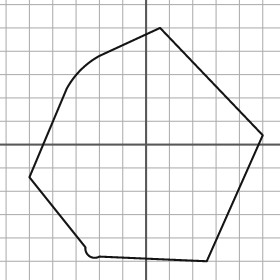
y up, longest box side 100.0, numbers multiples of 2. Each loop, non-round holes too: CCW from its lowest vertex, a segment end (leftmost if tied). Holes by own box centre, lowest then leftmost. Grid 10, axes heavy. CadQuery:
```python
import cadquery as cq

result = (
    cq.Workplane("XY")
    .moveTo(26.0, -50.0)
    .lineTo(50.0, 4.0)
    .lineTo(6.0, 50.0)
    .lineTo(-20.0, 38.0)
    .threePointArc((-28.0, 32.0), (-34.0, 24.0))
    .lineTo(-50.0, -14.0)
    .lineTo(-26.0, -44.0)
    .threePointArc((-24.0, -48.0), (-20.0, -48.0))
    .close()
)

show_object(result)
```